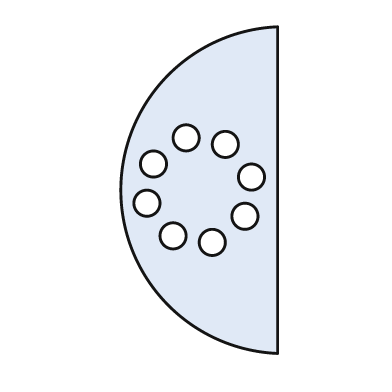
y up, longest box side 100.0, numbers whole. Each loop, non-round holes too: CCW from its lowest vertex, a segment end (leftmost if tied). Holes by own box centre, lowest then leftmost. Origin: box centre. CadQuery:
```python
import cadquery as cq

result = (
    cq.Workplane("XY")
    .moveTo(24.0, -50.0)
    .lineTo(24.0, 50.0)
    .threePointArc((-24.0, 0.0), (24.0, -50.0))
    .close()
    .moveTo(4.0, -16.0)
    .circle(4.0)
    .moveTo(-8.0, -14.0)
    .circle(4.0)
    .moveTo(14.0, -8.0)
    .circle(4.0)
    .moveTo(-16.0, -4.0)
    .circle(4.0)
    .moveTo(16.0, 4.0)
    .circle(4.0)
    .moveTo(-14.0, 8.0)
    .circle(4.0)
    .moveTo(8.0, 14.0)
    .circle(4.0)
    .moveTo(-4.0, 16.0)
    .circle(4.0)
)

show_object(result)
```